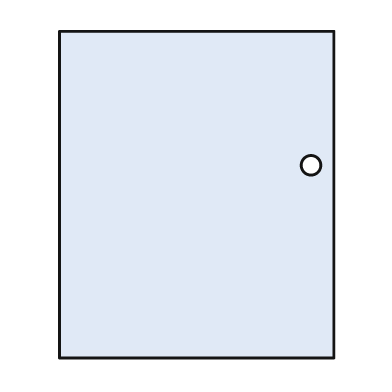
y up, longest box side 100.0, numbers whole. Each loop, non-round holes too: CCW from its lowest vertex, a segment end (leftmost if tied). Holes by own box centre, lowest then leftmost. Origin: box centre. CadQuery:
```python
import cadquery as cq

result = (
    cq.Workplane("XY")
    .moveTo(-42.0, -50.0)
    .lineTo(42.0, -50.0)
    .lineTo(42.0, 50.0)
    .lineTo(-42.0, 50.0)
    .close()
    .moveTo(35.0, 9.0)
    .circle(3.0)
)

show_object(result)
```